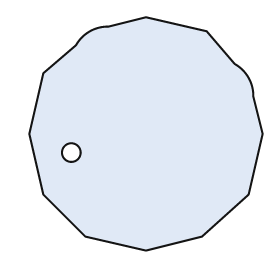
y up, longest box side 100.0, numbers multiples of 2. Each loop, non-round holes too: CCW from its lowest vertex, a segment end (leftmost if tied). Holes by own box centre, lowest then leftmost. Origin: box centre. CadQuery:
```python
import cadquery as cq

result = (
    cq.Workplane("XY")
    .moveTo(0.0, -50.0)
    .lineTo(24.0, -44.0)
    .lineTo(44.0, -26.0)
    .lineTo(50.0, 0.0)
    .lineTo(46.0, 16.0)
    .threePointArc((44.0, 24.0), (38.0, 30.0))
    .lineTo(26.0, 44.0)
    .lineTo(0.0, 50.0)
    .lineTo(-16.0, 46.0)
    .threePointArc((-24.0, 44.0), (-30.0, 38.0))
    .lineTo(-44.0, 26.0)
    .lineTo(-50.0, 0.0)
    .lineTo(-44.0, -26.0)
    .lineTo(-26.0, -44.0)
    .close()
    .moveTo(-32.0, -8.0)
    .circle(4.0)
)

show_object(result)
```